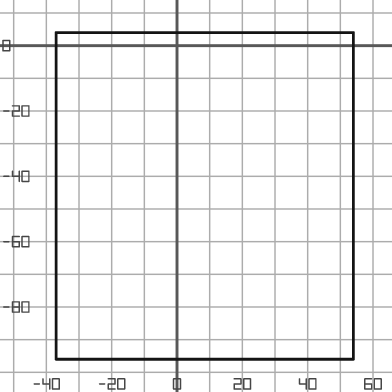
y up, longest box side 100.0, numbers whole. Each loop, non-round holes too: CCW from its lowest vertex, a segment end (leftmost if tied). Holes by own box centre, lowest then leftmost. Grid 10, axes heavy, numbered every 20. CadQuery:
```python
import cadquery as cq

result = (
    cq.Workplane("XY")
    .moveTo(-37.0, -96.0)
    .lineTo(54.0, -96.0)
    .lineTo(54.0, 4.0)
    .lineTo(-37.0, 4.0)
    .close()
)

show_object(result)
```